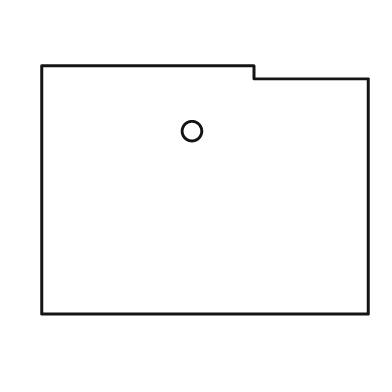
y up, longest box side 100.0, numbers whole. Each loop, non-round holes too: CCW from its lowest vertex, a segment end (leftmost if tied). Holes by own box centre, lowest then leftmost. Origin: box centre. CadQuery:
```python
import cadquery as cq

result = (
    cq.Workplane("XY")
    .moveTo(-50.0, -38.0)
    .lineTo(50.0, -38.0)
    .lineTo(50.0, 34.0)
    .lineTo(15.0, 34.0)
    .lineTo(15.0, 38.0)
    .lineTo(-50.0, 38.0)
    .close()
    .moveTo(-4.0, 18.0)
    .circle(3.0)
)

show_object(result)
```